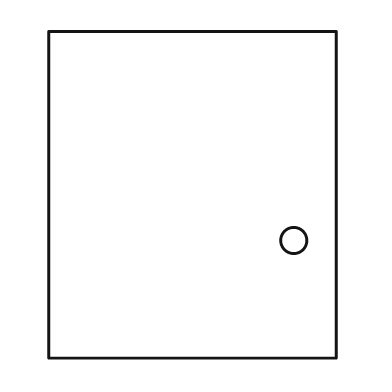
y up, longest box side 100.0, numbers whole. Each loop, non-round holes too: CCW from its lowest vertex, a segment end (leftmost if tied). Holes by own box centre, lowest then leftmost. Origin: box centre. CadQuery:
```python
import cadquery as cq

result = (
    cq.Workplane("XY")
    .moveTo(-44.0, -50.0)
    .lineTo(44.0, -50.0)
    .lineTo(44.0, 50.0)
    .lineTo(-44.0, 50.0)
    .close()
    .moveTo(31.0, -14.0)
    .circle(4.0)
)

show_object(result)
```